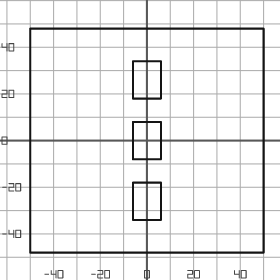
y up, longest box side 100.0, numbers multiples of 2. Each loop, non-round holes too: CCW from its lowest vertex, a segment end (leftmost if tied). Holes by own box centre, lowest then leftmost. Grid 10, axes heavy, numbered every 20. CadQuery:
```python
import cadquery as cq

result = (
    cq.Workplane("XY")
    .moveTo(-50.0, -48.0)
    .lineTo(50.0, -48.0)
    .lineTo(50.0, 48.0)
    .lineTo(-50.0, 48.0)
    .close()
    .moveTo(-6.0, -34.0)
    .lineTo(6.0, -34.0)
    .lineTo(6.0, -18.0)
    .lineTo(-6.0, -18.0)
    .close()
    .moveTo(-6.0, -8.0)
    .lineTo(6.0, -8.0)
    .lineTo(6.0, 8.0)
    .lineTo(-6.0, 8.0)
    .close()
    .moveTo(-6.0, 18.0)
    .lineTo(6.0, 18.0)
    .lineTo(6.0, 34.0)
    .lineTo(-6.0, 34.0)
    .close()
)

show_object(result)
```